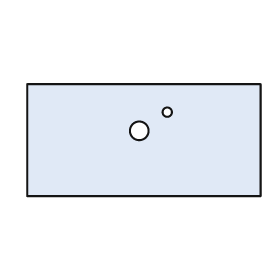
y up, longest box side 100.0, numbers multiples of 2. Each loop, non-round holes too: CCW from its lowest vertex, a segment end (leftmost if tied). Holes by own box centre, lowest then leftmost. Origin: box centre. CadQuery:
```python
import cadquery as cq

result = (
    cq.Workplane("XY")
    .moveTo(-50.0, -24.0)
    .lineTo(50.0, -24.0)
    .lineTo(50.0, 24.0)
    .lineTo(-50.0, 24.0)
    .close()
    .moveTo(-2.0, 4.0)
    .circle(4.0)
    .moveTo(10.0, 12.0)
    .circle(2.0)
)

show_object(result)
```